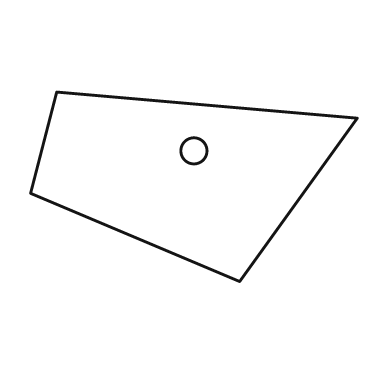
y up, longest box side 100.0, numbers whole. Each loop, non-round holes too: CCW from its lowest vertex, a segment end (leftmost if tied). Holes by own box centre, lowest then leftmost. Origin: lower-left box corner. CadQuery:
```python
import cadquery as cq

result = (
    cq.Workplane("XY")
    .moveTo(64.0, 0.0)
    .lineTo(100.0, 50.0)
    .lineTo(8.0, 58.0)
    .lineTo(0.0, 27.0)
    .close()
    .moveTo(50.0, 40.0)
    .circle(4.0)
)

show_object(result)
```